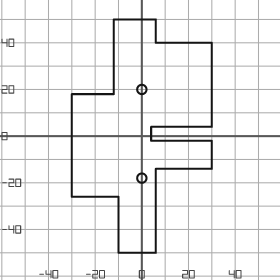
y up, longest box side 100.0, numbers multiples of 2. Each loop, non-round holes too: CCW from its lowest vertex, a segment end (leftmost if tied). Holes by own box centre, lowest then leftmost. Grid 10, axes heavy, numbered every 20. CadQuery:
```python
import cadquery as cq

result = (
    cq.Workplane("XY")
    .moveTo(-10.0, -50.0)
    .lineTo(6.0, -50.0)
    .lineTo(6.0, -14.0)
    .lineTo(30.0, -14.0)
    .lineTo(30.0, -2.0)
    .lineTo(4.0, -2.0)
    .lineTo(4.0, 4.0)
    .lineTo(30.0, 4.0)
    .lineTo(30.0, 40.0)
    .lineTo(6.0, 40.0)
    .lineTo(6.0, 50.0)
    .lineTo(-12.0, 50.0)
    .lineTo(-12.0, 18.0)
    .lineTo(-30.0, 18.0)
    .lineTo(-30.0, -26.0)
    .lineTo(-10.0, -26.0)
    .close()
    .moveTo(0.0, -18.0)
    .circle(2.0)
    .moveTo(0.0, 20.0)
    .circle(2.0)
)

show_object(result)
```